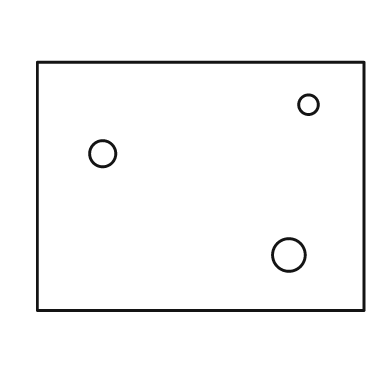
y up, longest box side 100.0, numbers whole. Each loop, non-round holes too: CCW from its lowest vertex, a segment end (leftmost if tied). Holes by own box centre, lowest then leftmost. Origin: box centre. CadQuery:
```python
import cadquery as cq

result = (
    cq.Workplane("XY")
    .moveTo(-50.0, -38.0)
    .lineTo(50.0, -38.0)
    .lineTo(50.0, 38.0)
    .lineTo(-50.0, 38.0)
    .close()
    .moveTo(27.0, -21.0)
    .circle(5.0)
    .moveTo(-30.0, 10.0)
    .circle(4.0)
    .moveTo(33.0, 25.0)
    .circle(3.0)
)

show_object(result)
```